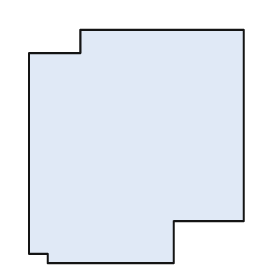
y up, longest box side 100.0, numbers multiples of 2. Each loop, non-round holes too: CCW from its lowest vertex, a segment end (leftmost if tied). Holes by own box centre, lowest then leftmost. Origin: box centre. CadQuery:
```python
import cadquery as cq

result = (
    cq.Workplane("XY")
    .moveTo(-38.0, -50.0)
    .lineTo(16.0, -50.0)
    .lineTo(16.0, -32.0)
    .lineTo(46.0, -32.0)
    .lineTo(46.0, 50.0)
    .lineTo(-24.0, 50.0)
    .lineTo(-24.0, 40.0)
    .lineTo(-46.0, 40.0)
    .lineTo(-46.0, -46.0)
    .lineTo(-38.0, -46.0)
    .close()
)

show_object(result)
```